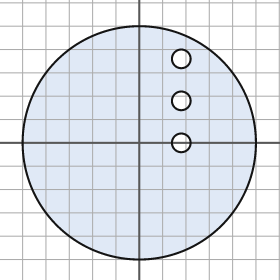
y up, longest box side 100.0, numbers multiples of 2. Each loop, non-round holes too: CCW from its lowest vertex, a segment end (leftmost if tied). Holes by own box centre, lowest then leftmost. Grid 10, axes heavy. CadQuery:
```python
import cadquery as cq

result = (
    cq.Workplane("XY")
    .moveTo(0.0, 0.0)
    .circle(50.0)
    .moveTo(18.0, 0.0)
    .circle(4.0)
    .moveTo(18.0, 18.0)
    .circle(4.0)
    .moveTo(18.0, 36.0)
    .circle(4.0)
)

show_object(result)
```